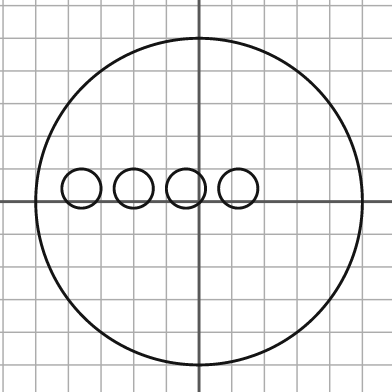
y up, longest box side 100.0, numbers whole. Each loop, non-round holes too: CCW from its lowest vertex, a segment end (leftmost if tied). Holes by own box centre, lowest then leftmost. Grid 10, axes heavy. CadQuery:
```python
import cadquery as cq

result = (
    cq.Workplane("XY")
    .moveTo(0.0, 0.0)
    .circle(50.0)
    .moveTo(-36.0, 4.0)
    .circle(6.0)
    .moveTo(-20.0, 4.0)
    .circle(6.0)
    .moveTo(-4.0, 4.0)
    .circle(6.0)
    .moveTo(12.0, 4.0)
    .circle(6.0)
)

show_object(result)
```